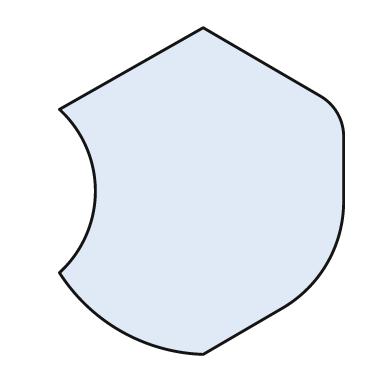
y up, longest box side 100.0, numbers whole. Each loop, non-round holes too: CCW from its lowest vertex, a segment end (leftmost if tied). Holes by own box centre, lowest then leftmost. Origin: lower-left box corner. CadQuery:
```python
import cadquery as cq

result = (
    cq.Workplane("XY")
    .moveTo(44.0, 0.0)
    .lineTo(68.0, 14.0)
    .threePointArc((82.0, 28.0), (87.0, 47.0))
    .lineTo(87.0, 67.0)
    .threePointArc((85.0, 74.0), (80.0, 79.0))
    .lineTo(44.0, 100.0)
    .lineTo(0.0, 75.0)
    .threePointArc((11.0, 50.0), (0.0, 25.0))
    .threePointArc((19.0, 7.0), (44.0, 0.0))
    .close()
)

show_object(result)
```